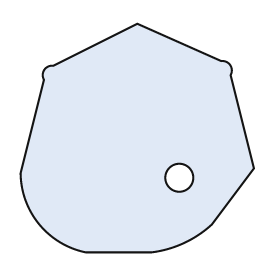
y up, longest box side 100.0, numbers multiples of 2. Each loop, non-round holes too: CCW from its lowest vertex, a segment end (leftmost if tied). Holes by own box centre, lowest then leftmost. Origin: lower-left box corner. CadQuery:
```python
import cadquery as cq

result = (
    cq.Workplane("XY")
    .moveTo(28.0, 0.0)
    .lineTo(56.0, 0.0)
    .threePointArc((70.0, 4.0), (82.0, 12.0))
    .lineTo(100.0, 36.0)
    .lineTo(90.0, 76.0)
    .threePointArc((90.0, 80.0), (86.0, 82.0))
    .lineTo(50.0, 98.0)
    .lineTo(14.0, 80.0)
    .threePointArc((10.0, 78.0), (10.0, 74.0))
    .lineTo(0.0, 34.0)
    .threePointArc((8.0, 12.0), (28.0, 0.0))
    .close()
    .moveTo(68.0, 32.0)
    .circle(6.0)
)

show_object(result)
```